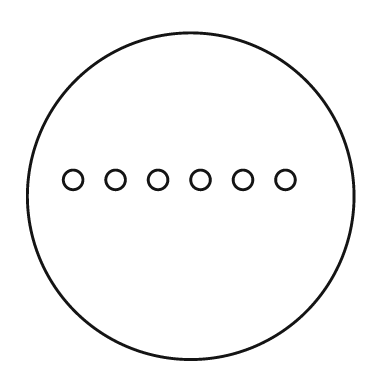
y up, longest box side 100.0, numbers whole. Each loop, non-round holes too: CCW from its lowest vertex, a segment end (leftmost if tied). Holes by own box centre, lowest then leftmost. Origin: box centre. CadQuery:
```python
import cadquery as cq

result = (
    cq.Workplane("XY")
    .moveTo(0.0, 0.0)
    .circle(50.0)
    .moveTo(-36.0, 5.0)
    .circle(3.0)
    .moveTo(-23.0, 5.0)
    .circle(3.0)
    .moveTo(-10.0, 5.0)
    .circle(3.0)
    .moveTo(3.0, 5.0)
    .circle(3.0)
    .moveTo(16.0, 5.0)
    .circle(3.0)
    .moveTo(29.0, 5.0)
    .circle(3.0)
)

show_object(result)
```